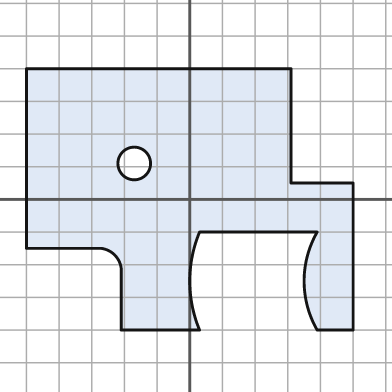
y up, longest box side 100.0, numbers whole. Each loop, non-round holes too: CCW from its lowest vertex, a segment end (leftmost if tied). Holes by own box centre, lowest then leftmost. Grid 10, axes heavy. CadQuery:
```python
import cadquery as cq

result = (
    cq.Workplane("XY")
    .moveTo(-21.0, -40.0)
    .lineTo(3.0, -40.0)
    .threePointArc((0.0, -25.0), (3.0, -10.0))
    .lineTo(39.0, -10.0)
    .threePointArc((35.0, -25.0), (39.0, -40.0))
    .lineTo(50.0, -40.0)
    .lineTo(50.0, 5.0)
    .lineTo(31.0, 5.0)
    .lineTo(31.0, 40.0)
    .lineTo(-50.0, 40.0)
    .lineTo(-50.0, -15.0)
    .lineTo(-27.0, -15.0)
    .threePointArc((-23.0, -17.0), (-21.0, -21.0))
    .close()
    .moveTo(-17.0, 11.0)
    .circle(5.0)
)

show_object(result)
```